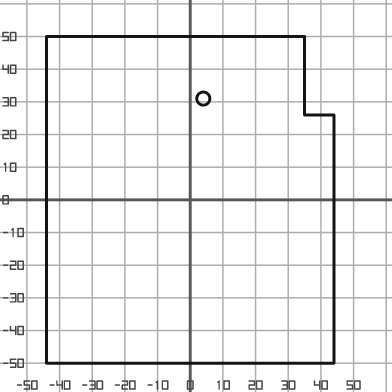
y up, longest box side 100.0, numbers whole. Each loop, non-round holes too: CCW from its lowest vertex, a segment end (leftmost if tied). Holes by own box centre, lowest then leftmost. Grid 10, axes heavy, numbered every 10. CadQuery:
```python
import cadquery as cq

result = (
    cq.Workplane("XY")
    .moveTo(-44.0, -50.0)
    .lineTo(44.0, -50.0)
    .lineTo(44.0, 26.0)
    .lineTo(35.0, 26.0)
    .lineTo(35.0, 50.0)
    .lineTo(-44.0, 50.0)
    .close()
    .moveTo(4.0, 31.0)
    .circle(2.0)
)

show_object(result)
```